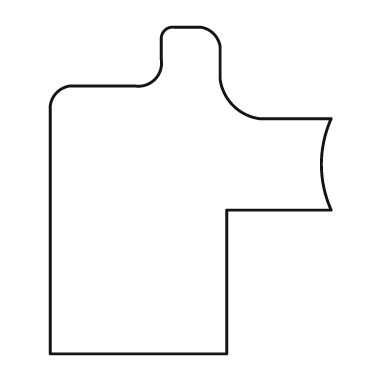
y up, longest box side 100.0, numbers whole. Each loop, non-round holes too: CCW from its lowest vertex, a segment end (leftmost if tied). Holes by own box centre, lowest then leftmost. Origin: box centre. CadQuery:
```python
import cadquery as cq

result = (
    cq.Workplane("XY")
    .moveTo(-43.0, -50.0)
    .lineTo(11.0, -50.0)
    .lineTo(11.0, -6.0)
    .lineTo(43.0, -6.0)
    .threePointArc((40.0, 8.0), (43.0, 22.0))
    .lineTo(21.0, 22.0)
    .threePointArc((13.0, 26.0), (9.0, 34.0))
    .lineTo(9.0, 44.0)
    .threePointArc((7.0, 48.0), (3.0, 50.0))
    .lineTo(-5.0, 50.0)
    .threePointArc((-8.0, 49.0), (-9.0, 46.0))
    .lineTo(-9.0, 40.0)
    .threePointArc((-11.0, 34.0), (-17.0, 32.0))
    .lineTo(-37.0, 32.0)
    .threePointArc((-41.0, 30.0), (-43.0, 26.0))
    .close()
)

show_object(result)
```